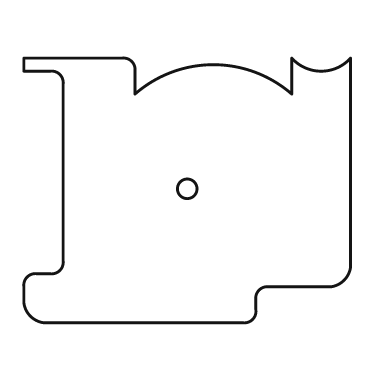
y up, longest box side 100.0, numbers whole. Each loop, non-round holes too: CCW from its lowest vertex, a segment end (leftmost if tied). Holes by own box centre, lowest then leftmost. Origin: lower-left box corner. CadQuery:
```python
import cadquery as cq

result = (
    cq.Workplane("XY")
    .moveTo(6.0, 0.0)
    .lineTo(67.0, 0.0)
    .threePointArc((70.0, 1.0), (71.0, 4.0))
    .lineTo(71.0, 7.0)
    .threePointArc((72.0, 10.0), (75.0, 11.0))
    .lineTo(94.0, 11.0)
    .threePointArc((98.0, 13.0), (100.0, 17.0))
    .lineTo(100.0, 81.0)
    .threePointArc((91.0, 77.0), (82.0, 81.0))
    .lineTo(82.0, 70.0)
    .threePointArc((58.0, 79.0), (34.0, 70.0))
    .lineTo(34.0, 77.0)
    .threePointArc((33.0, 80.0), (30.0, 81.0))
    .lineTo(0.0, 81.0)
    .lineTo(0.0, 77.0)
    .lineTo(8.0, 77.0)
    .threePointArc((11.0, 76.0), (12.0, 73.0))
    .lineTo(12.0, 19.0)
    .threePointArc((11.0, 16.0), (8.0, 15.0))
    .lineTo(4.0, 15.0)
    .threePointArc((1.0, 14.0), (0.0, 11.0))
    .lineTo(0.0, 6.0)
    .threePointArc((2.0, 2.0), (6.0, 0.0))
    .close()
    .moveTo(50.0, 41.0)
    .circle(3.0)
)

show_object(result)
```